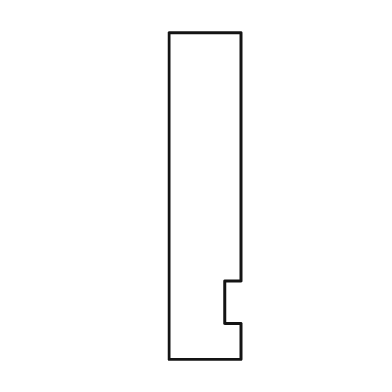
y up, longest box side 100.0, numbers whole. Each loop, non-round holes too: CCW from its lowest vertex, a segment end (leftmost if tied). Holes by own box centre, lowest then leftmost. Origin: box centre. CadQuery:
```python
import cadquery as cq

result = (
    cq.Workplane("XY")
    .moveTo(-11.0, -50.0)
    .lineTo(11.0, -50.0)
    .lineTo(11.0, -39.0)
    .lineTo(6.0, -39.0)
    .lineTo(6.0, -26.0)
    .lineTo(11.0, -26.0)
    .lineTo(11.0, 50.0)
    .lineTo(-11.0, 50.0)
    .close()
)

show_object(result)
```